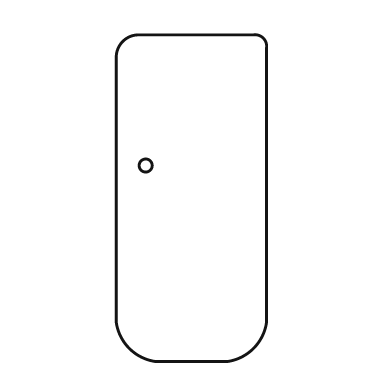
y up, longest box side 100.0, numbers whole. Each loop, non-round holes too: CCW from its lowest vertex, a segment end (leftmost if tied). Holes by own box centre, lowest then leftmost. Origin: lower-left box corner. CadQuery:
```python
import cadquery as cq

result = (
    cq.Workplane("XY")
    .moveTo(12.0, 0.0)
    .lineTo(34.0, 0.0)
    .threePointArc((42.0, 4.0), (46.0, 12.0))
    .lineTo(46.0, 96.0)
    .threePointArc((45.0, 99.0), (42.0, 100.0))
    .lineTo(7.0, 100.0)
    .threePointArc((2.0, 98.0), (0.0, 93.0))
    .lineTo(0.0, 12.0)
    .threePointArc((4.0, 4.0), (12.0, 0.0))
    .close()
    .moveTo(9.0, 60.0)
    .circle(2.0)
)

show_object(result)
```